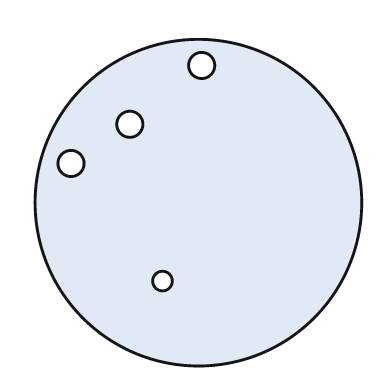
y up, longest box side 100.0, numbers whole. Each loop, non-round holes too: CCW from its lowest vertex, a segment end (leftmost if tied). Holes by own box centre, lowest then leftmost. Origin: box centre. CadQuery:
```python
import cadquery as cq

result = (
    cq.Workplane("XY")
    .moveTo(0.0, 0.0)
    .circle(50.0)
    .moveTo(-11.0, -24.0)
    .circle(3.0)
    .moveTo(-39.0, 12.0)
    .circle(4.0)
    .moveTo(-21.0, 24.0)
    .circle(4.0)
    .moveTo(1.0, 42.0)
    .circle(4.0)
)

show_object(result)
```